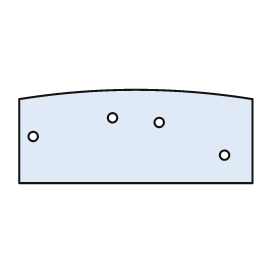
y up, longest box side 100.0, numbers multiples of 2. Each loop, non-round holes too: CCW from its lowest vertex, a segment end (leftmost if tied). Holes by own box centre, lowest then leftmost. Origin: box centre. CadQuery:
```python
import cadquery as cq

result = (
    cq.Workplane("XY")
    .moveTo(-50.0, -20.0)
    .lineTo(50.0, -20.0)
    .lineTo(50.0, 16.0)
    .threePointArc((0.0, 20.0), (-50.0, 16.0))
    .close()
    .moveTo(38.0, -8.0)
    .circle(2.0)
    .moveTo(-44.0, 0.0)
    .circle(2.0)
    .moveTo(10.0, 6.0)
    .circle(2.0)
    .moveTo(-10.0, 8.0)
    .circle(2.0)
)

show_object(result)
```